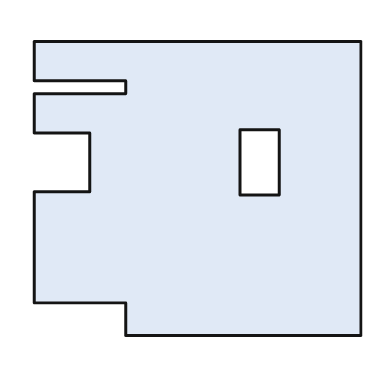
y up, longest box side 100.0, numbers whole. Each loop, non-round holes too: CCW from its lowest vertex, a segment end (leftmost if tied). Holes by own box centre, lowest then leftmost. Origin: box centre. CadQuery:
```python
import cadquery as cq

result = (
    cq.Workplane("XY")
    .moveTo(-22.0, -45.0)
    .lineTo(50.0, -45.0)
    .lineTo(50.0, 45.0)
    .lineTo(-50.0, 45.0)
    .lineTo(-50.0, 33.0)
    .lineTo(-22.0, 33.0)
    .lineTo(-22.0, 29.0)
    .lineTo(-50.0, 29.0)
    .lineTo(-50.0, 17.0)
    .lineTo(-33.0, 17.0)
    .lineTo(-33.0, -1.0)
    .lineTo(-50.0, -1.0)
    .lineTo(-50.0, -35.0)
    .lineTo(-22.0, -35.0)
    .close()
    .moveTo(13.0, -2.0)
    .lineTo(25.0, -2.0)
    .lineTo(25.0, 18.0)
    .lineTo(13.0, 18.0)
    .close()
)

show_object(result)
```